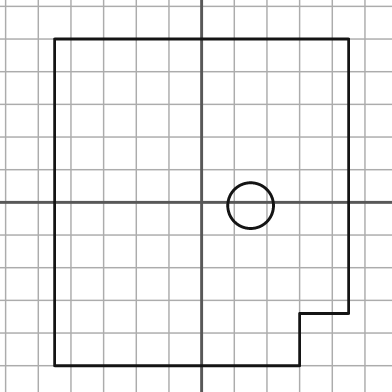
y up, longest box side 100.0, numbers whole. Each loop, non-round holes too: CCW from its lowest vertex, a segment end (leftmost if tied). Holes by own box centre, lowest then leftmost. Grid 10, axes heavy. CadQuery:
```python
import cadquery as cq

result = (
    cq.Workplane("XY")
    .moveTo(-45.0, -50.0)
    .lineTo(30.0, -50.0)
    .lineTo(30.0, -34.0)
    .lineTo(45.0, -34.0)
    .lineTo(45.0, 50.0)
    .lineTo(-45.0, 50.0)
    .close()
    .moveTo(15.0, -1.0)
    .circle(7.0)
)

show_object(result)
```